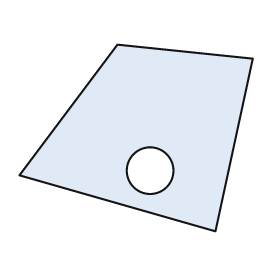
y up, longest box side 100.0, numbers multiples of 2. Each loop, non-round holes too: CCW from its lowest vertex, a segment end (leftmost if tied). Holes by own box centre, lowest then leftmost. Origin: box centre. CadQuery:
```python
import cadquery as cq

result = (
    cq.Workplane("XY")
    .moveTo(34.0, -40.0)
    .lineTo(50.0, 34.0)
    .lineTo(-8.0, 40.0)
    .lineTo(-50.0, -16.0)
    .close()
    .moveTo(6.0, -14.0)
    .circle(10.0)
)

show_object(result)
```